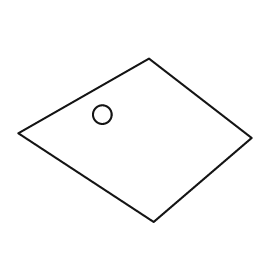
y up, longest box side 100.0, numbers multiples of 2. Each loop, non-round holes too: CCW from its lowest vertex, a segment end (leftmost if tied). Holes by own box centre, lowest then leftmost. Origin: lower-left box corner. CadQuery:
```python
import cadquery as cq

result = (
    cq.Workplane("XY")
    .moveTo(58.0, 0.0)
    .lineTo(100.0, 36.0)
    .lineTo(56.0, 70.0)
    .lineTo(0.0, 38.0)
    .close()
    .moveTo(36.0, 46.0)
    .circle(4.0)
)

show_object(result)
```